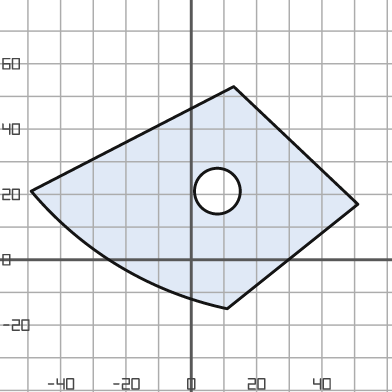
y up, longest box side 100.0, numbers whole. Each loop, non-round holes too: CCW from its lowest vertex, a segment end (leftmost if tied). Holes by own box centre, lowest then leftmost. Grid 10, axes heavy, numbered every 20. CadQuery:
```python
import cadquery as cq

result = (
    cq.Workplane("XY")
    .moveTo(11.0, -15.0)
    .lineTo(51.0, 17.0)
    .lineTo(13.0, 53.0)
    .lineTo(-49.0, 21.0)
    .threePointArc((-22.0, -2.0), (11.0, -15.0))
    .close()
    .moveTo(8.0, 21.0)
    .circle(7.0)
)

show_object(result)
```